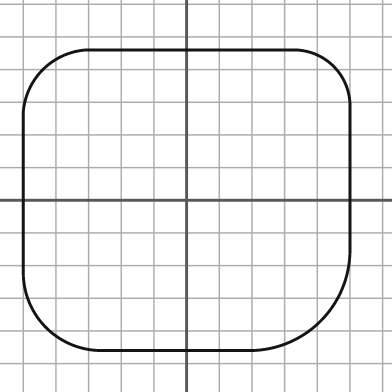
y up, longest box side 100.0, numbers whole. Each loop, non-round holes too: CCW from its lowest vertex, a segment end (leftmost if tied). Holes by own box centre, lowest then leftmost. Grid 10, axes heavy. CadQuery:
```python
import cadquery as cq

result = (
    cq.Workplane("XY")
    .moveTo(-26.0, -46.0)
    .lineTo(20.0, -46.0)
    .threePointArc((41.0, -37.0), (50.0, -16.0))
    .lineTo(50.0, 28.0)
    .threePointArc((45.0, 41.0), (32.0, 46.0))
    .lineTo(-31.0, 46.0)
    .threePointArc((-44.0, 40.0), (-50.0, 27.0))
    .lineTo(-50.0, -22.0)
    .threePointArc((-43.0, -39.0), (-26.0, -46.0))
    .close()
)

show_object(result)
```